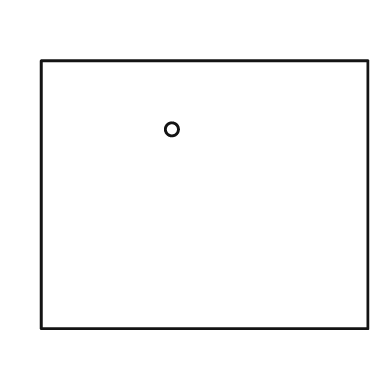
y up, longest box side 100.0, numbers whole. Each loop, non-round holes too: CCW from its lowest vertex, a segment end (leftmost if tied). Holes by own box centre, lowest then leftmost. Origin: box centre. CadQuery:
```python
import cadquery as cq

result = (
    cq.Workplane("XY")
    .moveTo(-50.0, -41.0)
    .lineTo(50.0, -41.0)
    .lineTo(50.0, 41.0)
    .lineTo(-50.0, 41.0)
    .close()
    .moveTo(-10.0, 20.0)
    .circle(2.0)
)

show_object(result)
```